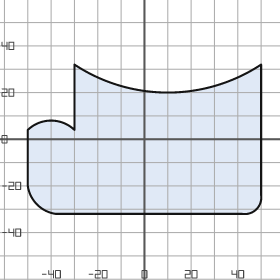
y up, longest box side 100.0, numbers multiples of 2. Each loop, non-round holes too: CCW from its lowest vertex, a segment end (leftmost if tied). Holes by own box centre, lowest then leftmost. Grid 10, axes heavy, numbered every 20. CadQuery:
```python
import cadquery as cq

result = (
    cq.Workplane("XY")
    .moveTo(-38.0, -32.0)
    .lineTo(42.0, -32.0)
    .threePointArc((48.0, -30.0), (50.0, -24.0))
    .lineTo(50.0, 32.0)
    .threePointArc((10.0, 20.0), (-30.0, 32.0))
    .lineTo(-30.0, 4.0)
    .threePointArc((-40.0, 8.0), (-50.0, 4.0))
    .lineTo(-50.0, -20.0)
    .threePointArc((-46.0, -28.0), (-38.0, -32.0))
    .close()
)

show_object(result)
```